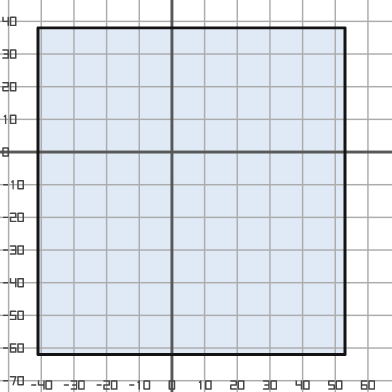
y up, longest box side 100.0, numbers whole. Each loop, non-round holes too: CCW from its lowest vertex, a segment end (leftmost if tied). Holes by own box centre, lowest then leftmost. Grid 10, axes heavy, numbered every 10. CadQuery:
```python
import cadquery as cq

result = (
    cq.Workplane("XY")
    .moveTo(-41.0, -62.0)
    .lineTo(53.0, -62.0)
    .lineTo(53.0, 38.0)
    .lineTo(-41.0, 38.0)
    .close()
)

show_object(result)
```